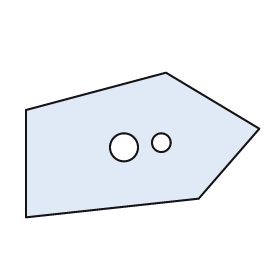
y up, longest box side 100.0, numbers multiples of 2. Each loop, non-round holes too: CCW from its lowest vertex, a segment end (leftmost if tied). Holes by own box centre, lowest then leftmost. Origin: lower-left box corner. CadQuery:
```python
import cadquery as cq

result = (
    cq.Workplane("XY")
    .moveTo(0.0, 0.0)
    .lineTo(74.0, 8.0)
    .lineTo(100.0, 38.0)
    .lineTo(60.0, 62.0)
    .lineTo(0.0, 46.0)
    .close()
    .moveTo(42.0, 30.0)
    .circle(6.0)
    .moveTo(58.0, 32.0)
    .circle(4.0)
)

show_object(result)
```